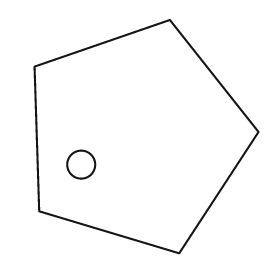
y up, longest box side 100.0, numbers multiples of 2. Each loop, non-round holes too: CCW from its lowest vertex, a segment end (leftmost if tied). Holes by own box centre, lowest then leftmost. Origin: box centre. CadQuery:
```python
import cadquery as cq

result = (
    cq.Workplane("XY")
    .moveTo(14.0, -50.0)
    .lineTo(48.0, 2.0)
    .lineTo(10.0, 50.0)
    .lineTo(-48.0, 30.0)
    .lineTo(-46.0, -32.0)
    .close()
    .moveTo(-28.0, -12.0)
    .circle(6.0)
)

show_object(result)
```